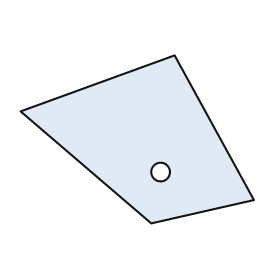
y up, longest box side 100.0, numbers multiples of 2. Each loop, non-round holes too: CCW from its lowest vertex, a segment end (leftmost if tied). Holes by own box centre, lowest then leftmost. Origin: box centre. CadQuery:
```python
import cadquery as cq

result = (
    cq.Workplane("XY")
    .moveTo(6.0, -36.0)
    .lineTo(50.0, -26.0)
    .lineTo(16.0, 36.0)
    .lineTo(-50.0, 12.0)
    .close()
    .moveTo(10.0, -14.0)
    .circle(4.0)
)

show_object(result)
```